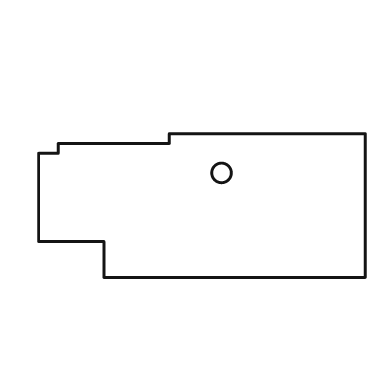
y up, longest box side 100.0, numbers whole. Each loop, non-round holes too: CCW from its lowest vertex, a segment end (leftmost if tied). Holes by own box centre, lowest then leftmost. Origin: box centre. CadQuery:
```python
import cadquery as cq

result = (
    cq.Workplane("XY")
    .moveTo(-30.0, -22.0)
    .lineTo(50.0, -22.0)
    .lineTo(50.0, 22.0)
    .lineTo(-10.0, 22.0)
    .lineTo(-10.0, 19.0)
    .lineTo(-44.0, 19.0)
    .lineTo(-44.0, 16.0)
    .lineTo(-50.0, 16.0)
    .lineTo(-50.0, -11.0)
    .lineTo(-30.0, -11.0)
    .close()
    .moveTo(6.0, 10.0)
    .circle(3.0)
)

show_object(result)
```